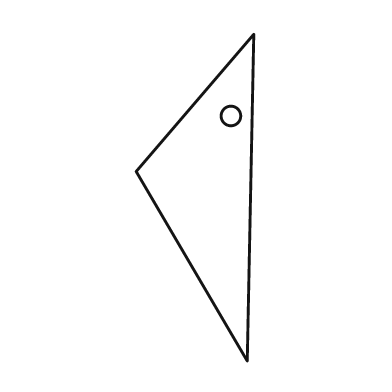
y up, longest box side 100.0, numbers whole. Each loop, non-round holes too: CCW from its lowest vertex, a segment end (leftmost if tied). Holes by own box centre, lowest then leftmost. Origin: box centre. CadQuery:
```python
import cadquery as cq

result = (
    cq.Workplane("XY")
    .moveTo(16.0, -50.0)
    .lineTo(18.0, 50.0)
    .lineTo(-18.0, 8.0)
    .close()
    .moveTo(11.0, 25.0)
    .circle(3.0)
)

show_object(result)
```